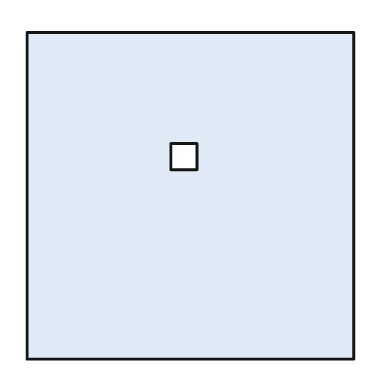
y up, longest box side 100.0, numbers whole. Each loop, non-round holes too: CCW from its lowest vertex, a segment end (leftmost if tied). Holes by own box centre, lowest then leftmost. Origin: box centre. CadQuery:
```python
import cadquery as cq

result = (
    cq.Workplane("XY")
    .moveTo(-50.0, -50.0)
    .lineTo(50.0, -50.0)
    .lineTo(50.0, 50.0)
    .lineTo(-50.0, 50.0)
    .close()
    .moveTo(-6.0, 8.0)
    .lineTo(2.0, 8.0)
    .lineTo(2.0, 16.0)
    .lineTo(-6.0, 16.0)
    .close()
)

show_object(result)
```